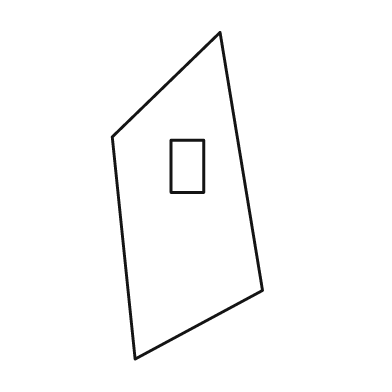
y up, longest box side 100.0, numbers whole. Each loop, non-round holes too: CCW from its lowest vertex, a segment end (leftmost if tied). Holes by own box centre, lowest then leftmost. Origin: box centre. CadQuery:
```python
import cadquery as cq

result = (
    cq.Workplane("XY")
    .moveTo(-16.0, -50.0)
    .lineTo(23.0, -29.0)
    .lineTo(10.0, 50.0)
    .lineTo(-23.0, 18.0)
    .close()
    .moveTo(-5.0, 1.0)
    .lineTo(5.0, 1.0)
    .lineTo(5.0, 17.0)
    .lineTo(-5.0, 17.0)
    .close()
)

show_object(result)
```